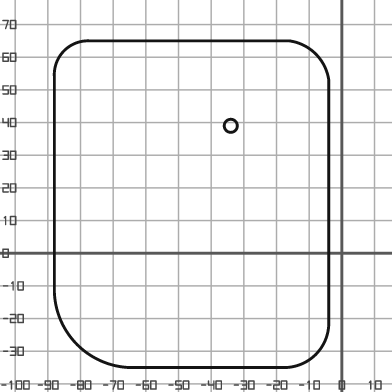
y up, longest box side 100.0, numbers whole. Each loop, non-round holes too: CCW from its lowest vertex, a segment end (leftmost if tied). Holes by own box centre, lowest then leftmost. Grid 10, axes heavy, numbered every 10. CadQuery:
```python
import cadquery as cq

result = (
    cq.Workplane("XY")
    .moveTo(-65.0, -35.0)
    .lineTo(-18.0, -35.0)
    .threePointArc((-8.0, -31.0), (-4.0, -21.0))
    .lineTo(-4.0, 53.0)
    .threePointArc((-8.0, 61.0), (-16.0, 65.0))
    .lineTo(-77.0, 65.0)
    .threePointArc((-85.0, 62.0), (-88.0, 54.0))
    .lineTo(-88.0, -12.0)
    .threePointArc((-81.0, -28.0), (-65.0, -35.0))
    .close()
    .moveTo(-34.0, 39.0)
    .circle(2.0)
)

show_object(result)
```